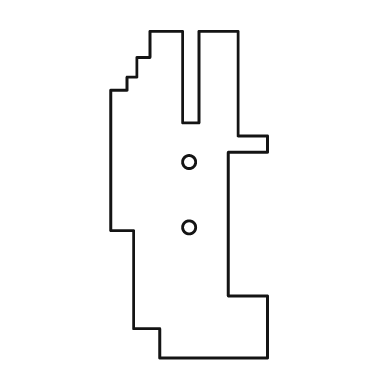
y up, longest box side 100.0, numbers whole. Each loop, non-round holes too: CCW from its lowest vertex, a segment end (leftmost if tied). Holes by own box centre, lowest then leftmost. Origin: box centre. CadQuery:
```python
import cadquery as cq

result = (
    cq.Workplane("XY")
    .moveTo(-9.0, -50.0)
    .lineTo(24.0, -50.0)
    .lineTo(24.0, -31.0)
    .lineTo(12.0, -31.0)
    .lineTo(12.0, 13.0)
    .lineTo(24.0, 13.0)
    .lineTo(24.0, 18.0)
    .lineTo(15.0, 18.0)
    .lineTo(15.0, 50.0)
    .lineTo(3.0, 50.0)
    .lineTo(3.0, 22.0)
    .lineTo(-2.0, 22.0)
    .lineTo(-2.0, 50.0)
    .lineTo(-12.0, 50.0)
    .lineTo(-12.0, 42.0)
    .lineTo(-16.0, 42.0)
    .lineTo(-16.0, 36.0)
    .lineTo(-19.0, 36.0)
    .lineTo(-19.0, 32.0)
    .lineTo(-24.0, 32.0)
    .lineTo(-24.0, -11.0)
    .lineTo(-17.0, -11.0)
    .lineTo(-17.0, -41.0)
    .lineTo(-9.0, -41.0)
    .close()
    .moveTo(0.0, -10.0)
    .circle(2.0)
    .moveTo(0.0, 10.0)
    .circle(2.0)
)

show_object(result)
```